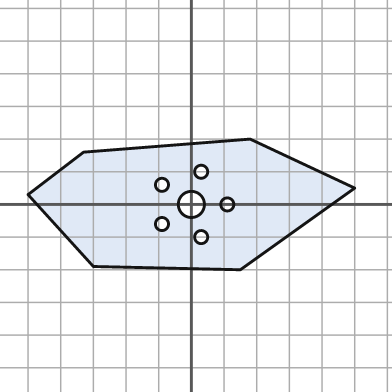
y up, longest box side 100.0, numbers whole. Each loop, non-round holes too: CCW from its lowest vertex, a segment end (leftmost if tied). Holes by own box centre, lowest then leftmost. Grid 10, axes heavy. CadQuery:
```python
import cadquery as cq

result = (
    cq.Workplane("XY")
    .moveTo(15.0, -20.0)
    .lineTo(50.0, 5.0)
    .lineTo(18.0, 20.0)
    .lineTo(-33.0, 16.0)
    .lineTo(-50.0, 3.0)
    .lineTo(-30.0, -19.0)
    .close()
    .moveTo(3.0, -10.0)
    .circle(2.0)
    .moveTo(-9.0, -6.0)
    .circle(2.0)
    .moveTo(0.0, 0.0)
    .circle(4.0)
    .moveTo(11.0, 0.0)
    .circle(2.0)
    .moveTo(-9.0, 6.0)
    .circle(2.0)
    .moveTo(3.0, 10.0)
    .circle(2.0)
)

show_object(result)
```